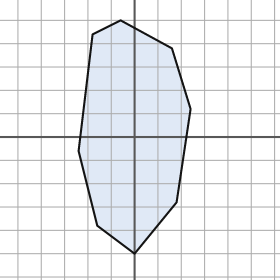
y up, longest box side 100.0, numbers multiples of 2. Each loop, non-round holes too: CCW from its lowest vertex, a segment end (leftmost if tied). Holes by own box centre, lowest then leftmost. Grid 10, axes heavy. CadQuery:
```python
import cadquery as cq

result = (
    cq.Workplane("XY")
    .moveTo(0.0, -50.0)
    .lineTo(18.0, -28.0)
    .lineTo(24.0, 12.0)
    .lineTo(16.0, 38.0)
    .lineTo(-6.0, 50.0)
    .lineTo(-18.0, 44.0)
    .lineTo(-24.0, -6.0)
    .lineTo(-16.0, -38.0)
    .close()
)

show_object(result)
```